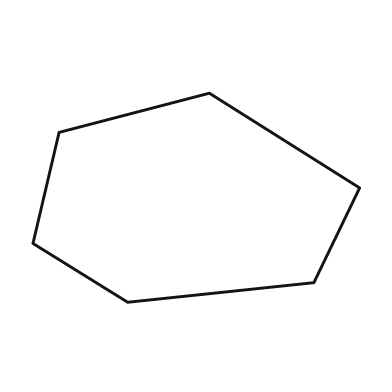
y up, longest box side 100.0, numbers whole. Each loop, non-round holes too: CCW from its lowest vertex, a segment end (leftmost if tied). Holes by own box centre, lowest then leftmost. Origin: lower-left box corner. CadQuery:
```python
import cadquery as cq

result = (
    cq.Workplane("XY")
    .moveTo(29.0, 0.0)
    .lineTo(86.0, 6.0)
    .lineTo(100.0, 35.0)
    .lineTo(54.0, 64.0)
    .lineTo(8.0, 52.0)
    .lineTo(0.0, 18.0)
    .close()
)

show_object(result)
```